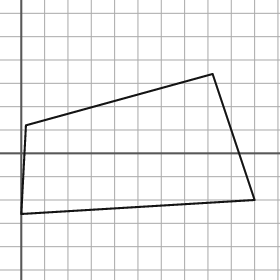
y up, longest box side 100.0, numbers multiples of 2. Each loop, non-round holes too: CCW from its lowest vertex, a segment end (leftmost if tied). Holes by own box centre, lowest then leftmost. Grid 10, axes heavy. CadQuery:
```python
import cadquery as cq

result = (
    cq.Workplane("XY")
    .moveTo(0.0, -26.0)
    .lineTo(100.0, -20.0)
    .lineTo(82.0, 34.0)
    .lineTo(2.0, 12.0)
    .close()
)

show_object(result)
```